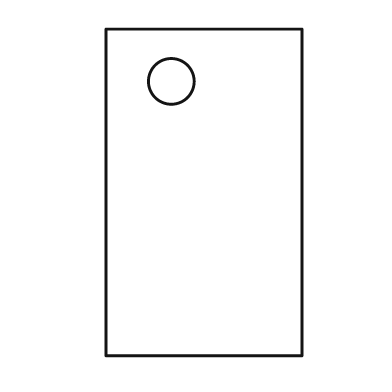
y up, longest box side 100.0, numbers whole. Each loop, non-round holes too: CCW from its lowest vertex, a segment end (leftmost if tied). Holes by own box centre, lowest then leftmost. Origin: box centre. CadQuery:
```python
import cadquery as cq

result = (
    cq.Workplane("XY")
    .moveTo(-30.0, -50.0)
    .lineTo(30.0, -50.0)
    .lineTo(30.0, 50.0)
    .lineTo(-30.0, 50.0)
    .close()
    .moveTo(-10.0, 34.0)
    .circle(7.0)
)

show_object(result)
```